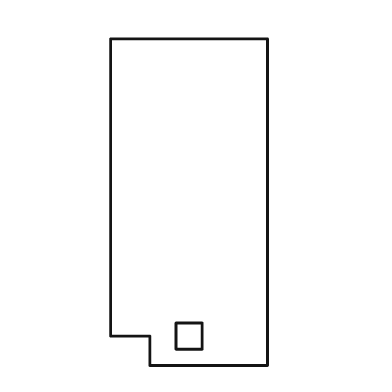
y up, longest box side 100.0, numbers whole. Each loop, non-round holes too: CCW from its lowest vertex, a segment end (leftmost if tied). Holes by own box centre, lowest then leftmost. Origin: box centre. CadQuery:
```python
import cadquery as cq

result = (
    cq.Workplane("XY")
    .moveTo(-12.0, -50.0)
    .lineTo(24.0, -50.0)
    .lineTo(24.0, 50.0)
    .lineTo(-24.0, 50.0)
    .lineTo(-24.0, -41.0)
    .lineTo(-12.0, -41.0)
    .close()
    .moveTo(-4.0, -45.0)
    .lineTo(4.0, -45.0)
    .lineTo(4.0, -37.0)
    .lineTo(-4.0, -37.0)
    .close()
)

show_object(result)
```